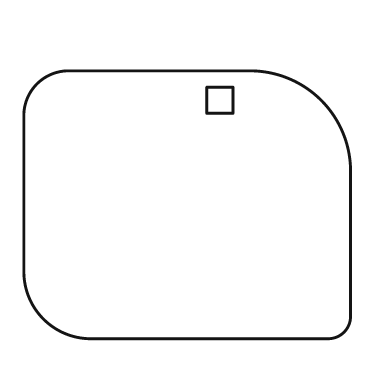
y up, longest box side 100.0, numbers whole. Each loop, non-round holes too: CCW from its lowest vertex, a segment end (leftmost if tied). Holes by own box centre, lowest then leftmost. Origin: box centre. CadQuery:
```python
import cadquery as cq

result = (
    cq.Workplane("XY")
    .moveTo(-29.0, -41.0)
    .lineTo(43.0, -41.0)
    .threePointArc((48.0, -39.0), (50.0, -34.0))
    .lineTo(50.0, 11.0)
    .threePointArc((41.0, 32.0), (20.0, 41.0))
    .lineTo(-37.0, 41.0)
    .threePointArc((-46.0, 37.0), (-50.0, 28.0))
    .lineTo(-50.0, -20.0)
    .threePointArc((-44.0, -35.0), (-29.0, -41.0))
    .close()
    .moveTo(6.0, 28.0)
    .lineTo(14.0, 28.0)
    .lineTo(14.0, 36.0)
    .lineTo(6.0, 36.0)
    .close()
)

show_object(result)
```